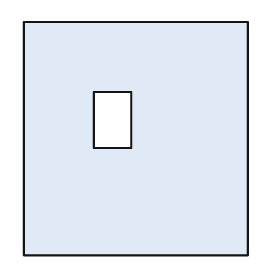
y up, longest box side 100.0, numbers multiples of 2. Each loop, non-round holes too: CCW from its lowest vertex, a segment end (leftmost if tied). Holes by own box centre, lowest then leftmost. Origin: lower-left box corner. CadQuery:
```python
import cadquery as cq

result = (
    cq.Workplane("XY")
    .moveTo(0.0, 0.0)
    .lineTo(96.0, 0.0)
    .lineTo(96.0, 100.0)
    .lineTo(0.0, 100.0)
    .close()
    .moveTo(30.0, 46.0)
    .lineTo(46.0, 46.0)
    .lineTo(46.0, 70.0)
    .lineTo(30.0, 70.0)
    .close()
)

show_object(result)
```